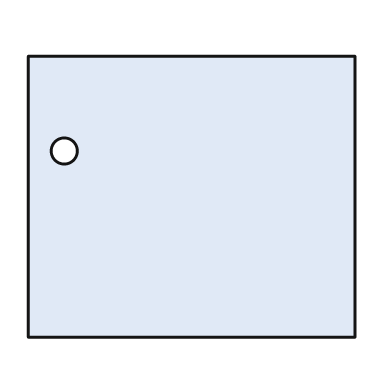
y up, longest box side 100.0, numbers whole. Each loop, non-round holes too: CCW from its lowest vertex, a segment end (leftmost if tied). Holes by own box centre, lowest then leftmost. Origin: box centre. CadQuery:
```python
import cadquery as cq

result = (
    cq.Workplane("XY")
    .moveTo(-50.0, -43.0)
    .lineTo(50.0, -43.0)
    .lineTo(50.0, 43.0)
    .lineTo(-50.0, 43.0)
    .close()
    .moveTo(-39.0, 14.0)
    .circle(4.0)
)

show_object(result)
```